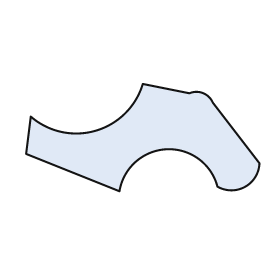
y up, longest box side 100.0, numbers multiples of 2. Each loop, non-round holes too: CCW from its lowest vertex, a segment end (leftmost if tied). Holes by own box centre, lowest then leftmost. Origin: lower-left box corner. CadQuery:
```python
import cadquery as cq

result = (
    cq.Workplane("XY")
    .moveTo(40.0, 0.0)
    .threePointArc((60.0, 18.0), (82.0, 2.0))
    .threePointArc((94.0, 2.0), (100.0, 12.0))
    .lineTo(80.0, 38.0)
    .threePointArc((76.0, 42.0), (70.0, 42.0))
    .lineTo(50.0, 46.0)
    .threePointArc((30.0, 26.0), (2.0, 32.0))
    .lineTo(0.0, 16.0)
    .close()
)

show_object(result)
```